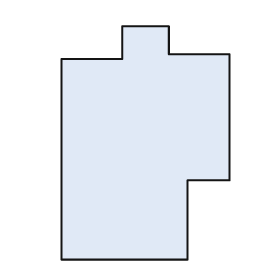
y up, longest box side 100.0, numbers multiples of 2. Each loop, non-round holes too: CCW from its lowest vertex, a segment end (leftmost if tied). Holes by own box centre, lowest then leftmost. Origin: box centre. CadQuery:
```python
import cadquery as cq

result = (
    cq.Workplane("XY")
    .moveTo(-36.0, -50.0)
    .lineTo(18.0, -50.0)
    .lineTo(18.0, -16.0)
    .lineTo(36.0, -16.0)
    .lineTo(36.0, 38.0)
    .lineTo(10.0, 38.0)
    .lineTo(10.0, 50.0)
    .lineTo(-10.0, 50.0)
    .lineTo(-10.0, 36.0)
    .lineTo(-36.0, 36.0)
    .close()
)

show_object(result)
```